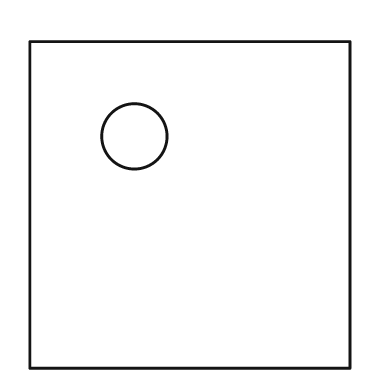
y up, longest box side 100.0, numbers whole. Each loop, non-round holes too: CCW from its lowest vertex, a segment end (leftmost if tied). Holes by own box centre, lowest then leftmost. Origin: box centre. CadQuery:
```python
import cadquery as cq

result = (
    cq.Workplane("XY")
    .moveTo(-49.0, -50.0)
    .lineTo(49.0, -50.0)
    .lineTo(49.0, 50.0)
    .lineTo(-49.0, 50.0)
    .close()
    .moveTo(-17.0, 21.0)
    .circle(10.0)
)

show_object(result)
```